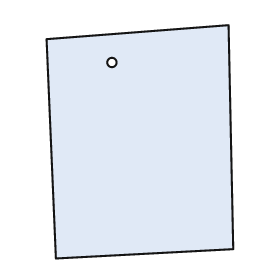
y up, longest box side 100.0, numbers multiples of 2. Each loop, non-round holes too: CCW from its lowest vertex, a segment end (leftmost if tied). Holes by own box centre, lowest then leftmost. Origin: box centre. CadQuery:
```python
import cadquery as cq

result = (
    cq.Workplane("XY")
    .moveTo(-36.0, -50.0)
    .lineTo(40.0, -46.0)
    .lineTo(38.0, 50.0)
    .lineTo(-40.0, 44.0)
    .close()
    .moveTo(-12.0, 34.0)
    .circle(2.0)
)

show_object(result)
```